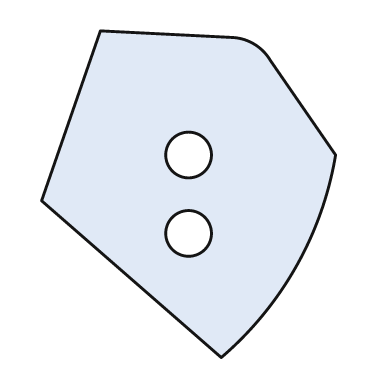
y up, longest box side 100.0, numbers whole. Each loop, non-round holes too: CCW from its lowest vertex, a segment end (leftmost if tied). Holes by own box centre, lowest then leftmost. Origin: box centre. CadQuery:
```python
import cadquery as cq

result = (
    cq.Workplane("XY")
    .moveTo(10.0, -50.0)
    .threePointArc((33.0, -22.0), (45.0, 12.0))
    .lineTo(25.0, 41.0)
    .threePointArc((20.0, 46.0), (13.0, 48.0))
    .lineTo(-27.0, 50.0)
    .lineTo(-45.0, -2.0)
    .close()
    .moveTo(0.0, -12.0)
    .circle(7.0)
    .moveTo(0.0, 12.0)
    .circle(7.0)
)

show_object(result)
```